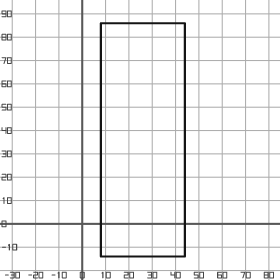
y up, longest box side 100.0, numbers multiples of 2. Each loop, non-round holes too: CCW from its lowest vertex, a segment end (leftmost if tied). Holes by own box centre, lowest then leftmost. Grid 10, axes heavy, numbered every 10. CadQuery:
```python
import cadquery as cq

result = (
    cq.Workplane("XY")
    .moveTo(8.0, -14.0)
    .lineTo(44.0, -14.0)
    .lineTo(44.0, 86.0)
    .lineTo(8.0, 86.0)
    .close()
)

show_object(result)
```